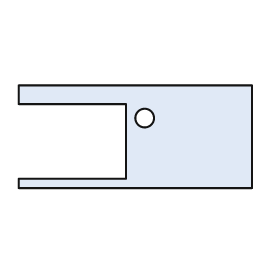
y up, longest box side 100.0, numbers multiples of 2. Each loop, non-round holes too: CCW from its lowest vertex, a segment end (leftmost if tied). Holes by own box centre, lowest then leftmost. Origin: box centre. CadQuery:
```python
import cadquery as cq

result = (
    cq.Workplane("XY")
    .moveTo(-50.0, -22.0)
    .lineTo(50.0, -22.0)
    .lineTo(50.0, 22.0)
    .lineTo(-50.0, 22.0)
    .lineTo(-50.0, 14.0)
    .lineTo(-4.0, 14.0)
    .lineTo(-4.0, -18.0)
    .lineTo(-50.0, -18.0)
    .close()
    .moveTo(4.0, 8.0)
    .circle(4.0)
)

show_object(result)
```